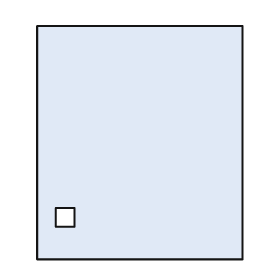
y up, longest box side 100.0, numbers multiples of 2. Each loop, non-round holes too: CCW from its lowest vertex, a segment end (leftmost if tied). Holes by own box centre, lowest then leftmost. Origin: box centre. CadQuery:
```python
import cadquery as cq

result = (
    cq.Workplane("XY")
    .moveTo(-44.0, -50.0)
    .lineTo(44.0, -50.0)
    .lineTo(44.0, 50.0)
    .lineTo(-44.0, 50.0)
    .close()
    .moveTo(-36.0, -36.0)
    .lineTo(-28.0, -36.0)
    .lineTo(-28.0, -28.0)
    .lineTo(-36.0, -28.0)
    .close()
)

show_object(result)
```